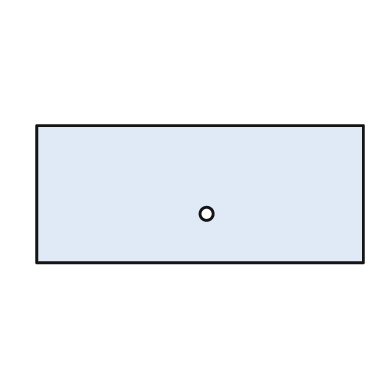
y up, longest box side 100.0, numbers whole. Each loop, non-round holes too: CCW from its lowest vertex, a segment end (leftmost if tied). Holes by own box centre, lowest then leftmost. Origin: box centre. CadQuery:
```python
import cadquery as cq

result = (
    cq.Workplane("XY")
    .moveTo(-50.0, -21.0)
    .lineTo(50.0, -21.0)
    .lineTo(50.0, 21.0)
    .lineTo(-50.0, 21.0)
    .close()
    .moveTo(2.0, -6.0)
    .circle(2.0)
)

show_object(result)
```